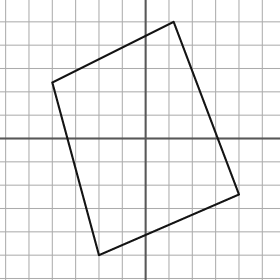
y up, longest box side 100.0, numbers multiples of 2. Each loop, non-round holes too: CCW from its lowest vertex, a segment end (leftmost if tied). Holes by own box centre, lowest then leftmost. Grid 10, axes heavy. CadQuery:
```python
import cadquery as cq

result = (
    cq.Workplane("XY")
    .moveTo(-20.0, -50.0)
    .lineTo(40.0, -24.0)
    .lineTo(12.0, 50.0)
    .lineTo(-40.0, 24.0)
    .close()
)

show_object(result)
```